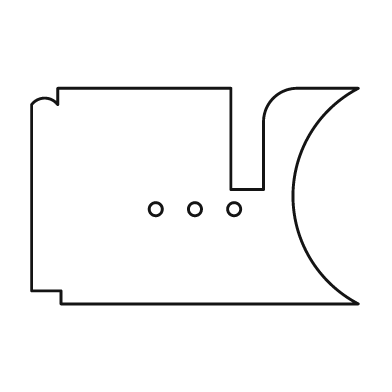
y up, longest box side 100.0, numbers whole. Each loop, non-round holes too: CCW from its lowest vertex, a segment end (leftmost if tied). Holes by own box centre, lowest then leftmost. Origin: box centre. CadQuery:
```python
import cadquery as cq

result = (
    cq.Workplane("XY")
    .moveTo(-41.0, -33.0)
    .lineTo(50.0, -33.0)
    .threePointArc((30.0, 0.0), (50.0, 33.0))
    .lineTo(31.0, 33.0)
    .threePointArc((24.0, 30.0), (21.0, 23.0))
    .lineTo(21.0, 2.0)
    .lineTo(11.0, 2.0)
    .lineTo(11.0, 33.0)
    .lineTo(-42.0, 33.0)
    .lineTo(-42.0, 28.0)
    .threePointArc((-46.0, 30.0), (-50.0, 28.0))
    .lineTo(-50.0, -29.0)
    .lineTo(-41.0, -29.0)
    .close()
    .moveTo(-12.0, -4.0)
    .circle(2.0)
    .moveTo(0.0, -4.0)
    .circle(2.0)
    .moveTo(12.0, -4.0)
    .circle(2.0)
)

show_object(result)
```